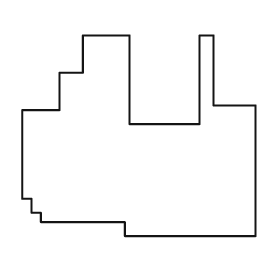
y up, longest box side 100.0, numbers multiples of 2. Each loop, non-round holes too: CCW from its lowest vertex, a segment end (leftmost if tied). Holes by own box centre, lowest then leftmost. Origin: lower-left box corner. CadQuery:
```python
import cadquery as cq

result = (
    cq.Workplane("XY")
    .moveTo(44.0, 0.0)
    .lineTo(100.0, 0.0)
    .lineTo(100.0, 56.0)
    .lineTo(82.0, 56.0)
    .lineTo(82.0, 86.0)
    .lineTo(76.0, 86.0)
    .lineTo(76.0, 48.0)
    .lineTo(46.0, 48.0)
    .lineTo(46.0, 86.0)
    .lineTo(26.0, 86.0)
    .lineTo(26.0, 70.0)
    .lineTo(16.0, 70.0)
    .lineTo(16.0, 54.0)
    .lineTo(0.0, 54.0)
    .lineTo(0.0, 16.0)
    .lineTo(4.0, 16.0)
    .lineTo(4.0, 10.0)
    .lineTo(8.0, 10.0)
    .lineTo(8.0, 6.0)
    .lineTo(44.0, 6.0)
    .close()
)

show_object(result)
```